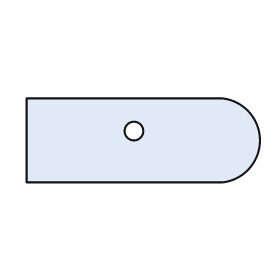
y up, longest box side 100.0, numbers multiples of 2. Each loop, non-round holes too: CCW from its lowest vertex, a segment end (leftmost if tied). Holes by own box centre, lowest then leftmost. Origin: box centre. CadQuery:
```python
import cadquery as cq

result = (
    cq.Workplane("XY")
    .moveTo(-50.0, -18.0)
    .lineTo(34.0, -18.0)
    .threePointArc((50.0, 0.0), (34.0, 18.0))
    .lineTo(-50.0, 18.0)
    .close()
    .moveTo(-4.0, 4.0)
    .circle(4.0)
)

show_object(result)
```